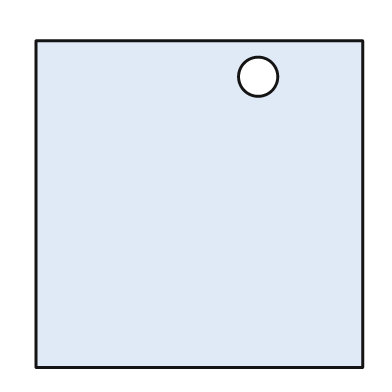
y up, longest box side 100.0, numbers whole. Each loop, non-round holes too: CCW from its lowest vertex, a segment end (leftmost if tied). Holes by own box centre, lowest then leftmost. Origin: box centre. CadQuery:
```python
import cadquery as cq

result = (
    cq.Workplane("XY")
    .moveTo(-50.0, -50.0)
    .lineTo(50.0, -50.0)
    .lineTo(50.0, 50.0)
    .lineTo(-50.0, 50.0)
    .close()
    .moveTo(18.0, 39.0)
    .circle(6.0)
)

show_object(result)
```